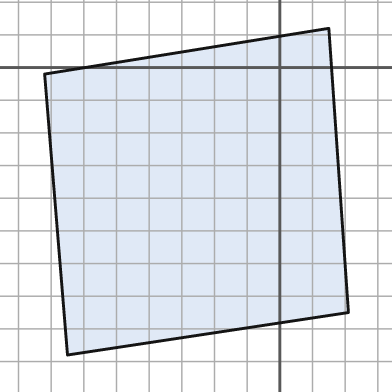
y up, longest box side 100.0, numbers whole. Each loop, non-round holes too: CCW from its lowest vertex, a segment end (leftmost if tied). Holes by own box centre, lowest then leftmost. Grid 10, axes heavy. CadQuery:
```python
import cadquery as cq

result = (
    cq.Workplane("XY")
    .moveTo(-65.0, -88.0)
    .lineTo(21.0, -75.0)
    .lineTo(15.0, 12.0)
    .lineTo(-72.0, -2.0)
    .close()
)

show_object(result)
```